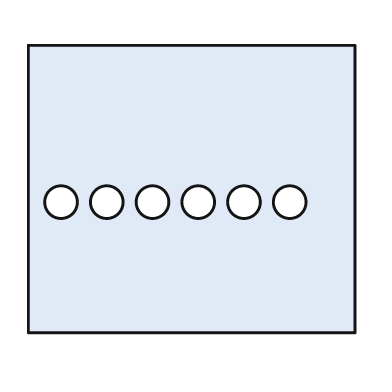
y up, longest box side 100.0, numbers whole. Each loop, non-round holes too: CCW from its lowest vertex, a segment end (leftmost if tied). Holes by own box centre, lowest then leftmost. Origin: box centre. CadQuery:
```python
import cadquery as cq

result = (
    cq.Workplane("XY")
    .moveTo(-50.0, -44.0)
    .lineTo(50.0, -44.0)
    .lineTo(50.0, 44.0)
    .lineTo(-50.0, 44.0)
    .close()
    .moveTo(-40.0, -4.0)
    .circle(5.0)
    .moveTo(-26.0, -4.0)
    .circle(5.0)
    .moveTo(-12.0, -4.0)
    .circle(5.0)
    .moveTo(2.0, -4.0)
    .circle(5.0)
    .moveTo(16.0, -4.0)
    .circle(5.0)
    .moveTo(30.0, -4.0)
    .circle(5.0)
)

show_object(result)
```